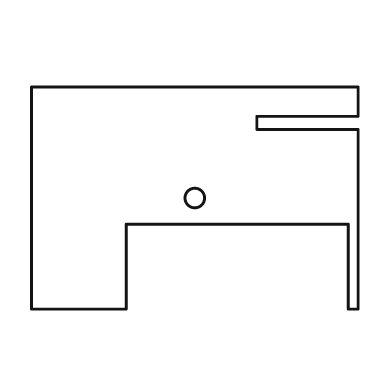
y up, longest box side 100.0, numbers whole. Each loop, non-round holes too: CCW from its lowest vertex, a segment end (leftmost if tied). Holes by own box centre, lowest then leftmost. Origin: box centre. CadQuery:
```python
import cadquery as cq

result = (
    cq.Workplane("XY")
    .moveTo(-50.0, -34.0)
    .lineTo(-21.0, -34.0)
    .lineTo(-21.0, -8.0)
    .lineTo(47.0, -8.0)
    .lineTo(47.0, -34.0)
    .lineTo(50.0, -34.0)
    .lineTo(50.0, 21.0)
    .lineTo(19.0, 21.0)
    .lineTo(19.0, 25.0)
    .lineTo(50.0, 25.0)
    .lineTo(50.0, 34.0)
    .lineTo(-50.0, 34.0)
    .close()
    .moveTo(0.0, 0.0)
    .circle(3.0)
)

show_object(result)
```